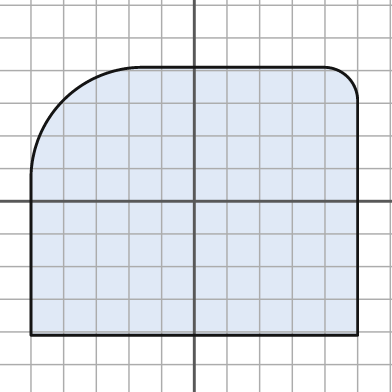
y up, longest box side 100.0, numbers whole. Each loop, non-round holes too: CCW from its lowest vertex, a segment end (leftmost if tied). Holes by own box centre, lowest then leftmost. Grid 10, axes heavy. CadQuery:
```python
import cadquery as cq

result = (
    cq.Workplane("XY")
    .moveTo(-50.0, -41.0)
    .lineTo(50.0, -41.0)
    .lineTo(50.0, 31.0)
    .threePointArc((47.0, 38.0), (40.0, 41.0))
    .lineTo(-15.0, 41.0)
    .threePointArc((-40.0, 31.0), (-50.0, 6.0))
    .close()
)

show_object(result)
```